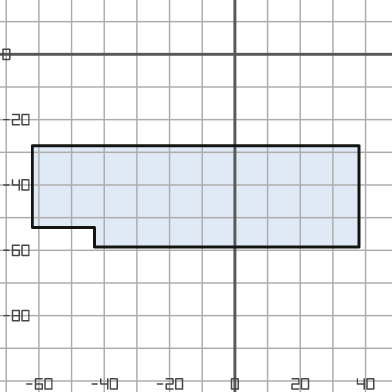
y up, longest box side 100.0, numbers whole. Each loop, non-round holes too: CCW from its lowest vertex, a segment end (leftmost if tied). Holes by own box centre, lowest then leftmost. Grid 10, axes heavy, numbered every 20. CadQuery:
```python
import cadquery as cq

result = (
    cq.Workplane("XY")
    .moveTo(-43.0, -59.0)
    .lineTo(38.0, -59.0)
    .lineTo(38.0, -28.0)
    .lineTo(-62.0, -28.0)
    .lineTo(-62.0, -53.0)
    .lineTo(-43.0, -53.0)
    .close()
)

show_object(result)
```